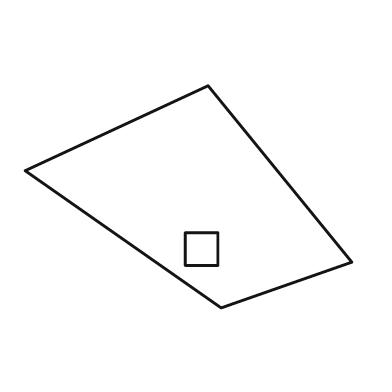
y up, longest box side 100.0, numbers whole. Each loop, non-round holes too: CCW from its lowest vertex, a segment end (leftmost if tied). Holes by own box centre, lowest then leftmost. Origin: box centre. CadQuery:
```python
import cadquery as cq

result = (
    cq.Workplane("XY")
    .moveTo(10.0, -34.0)
    .lineTo(50.0, -20.0)
    .lineTo(6.0, 34.0)
    .lineTo(-50.0, 8.0)
    .close()
    .moveTo(-1.0, -21.0)
    .lineTo(9.0, -21.0)
    .lineTo(9.0, -11.0)
    .lineTo(-1.0, -11.0)
    .close()
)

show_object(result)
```